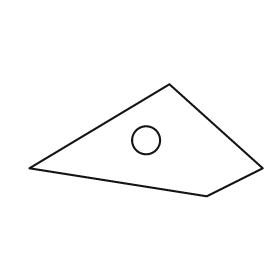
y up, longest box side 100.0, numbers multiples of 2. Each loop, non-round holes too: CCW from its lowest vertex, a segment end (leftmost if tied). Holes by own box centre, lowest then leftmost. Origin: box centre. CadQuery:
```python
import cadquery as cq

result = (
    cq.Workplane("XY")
    .moveTo(26.0, -24.0)
    .lineTo(50.0, -12.0)
    .lineTo(10.0, 24.0)
    .lineTo(-50.0, -12.0)
    .close()
    .moveTo(0.0, 0.0)
    .circle(6.0)
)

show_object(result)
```